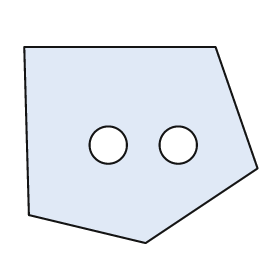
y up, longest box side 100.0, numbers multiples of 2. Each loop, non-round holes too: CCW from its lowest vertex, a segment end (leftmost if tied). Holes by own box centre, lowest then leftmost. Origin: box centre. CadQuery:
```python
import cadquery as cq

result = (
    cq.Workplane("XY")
    .moveTo(2.0, -42.0)
    .lineTo(50.0, -10.0)
    .lineTo(32.0, 42.0)
    .lineTo(-50.0, 42.0)
    .lineTo(-48.0, -30.0)
    .close()
    .moveTo(-14.0, 0.0)
    .circle(8.0)
    .moveTo(16.0, 0.0)
    .circle(8.0)
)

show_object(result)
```